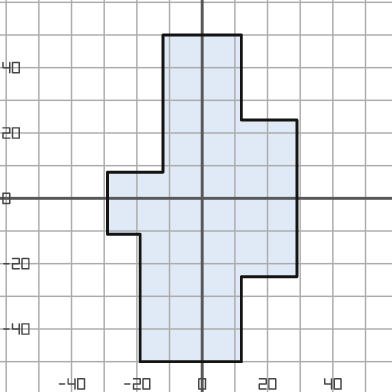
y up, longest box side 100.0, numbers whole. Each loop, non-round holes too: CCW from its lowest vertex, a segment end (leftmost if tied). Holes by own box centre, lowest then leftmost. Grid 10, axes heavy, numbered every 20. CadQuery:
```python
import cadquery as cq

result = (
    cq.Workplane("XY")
    .moveTo(-19.0, -50.0)
    .lineTo(12.0, -50.0)
    .lineTo(12.0, -24.0)
    .lineTo(29.0, -24.0)
    .lineTo(29.0, 24.0)
    .lineTo(12.0, 24.0)
    .lineTo(12.0, 50.0)
    .lineTo(-12.0, 50.0)
    .lineTo(-12.0, 8.0)
    .lineTo(-29.0, 8.0)
    .lineTo(-29.0, -11.0)
    .lineTo(-19.0, -11.0)
    .close()
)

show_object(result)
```